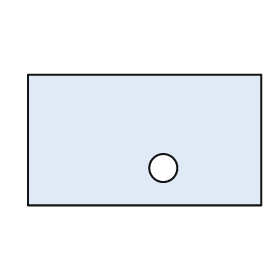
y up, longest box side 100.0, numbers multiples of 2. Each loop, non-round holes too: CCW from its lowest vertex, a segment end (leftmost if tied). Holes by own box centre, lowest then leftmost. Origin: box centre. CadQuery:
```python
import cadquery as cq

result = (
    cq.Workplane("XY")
    .moveTo(-50.0, -28.0)
    .lineTo(50.0, -28.0)
    .lineTo(50.0, 28.0)
    .lineTo(-50.0, 28.0)
    .close()
    .moveTo(8.0, -12.0)
    .circle(6.0)
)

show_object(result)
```